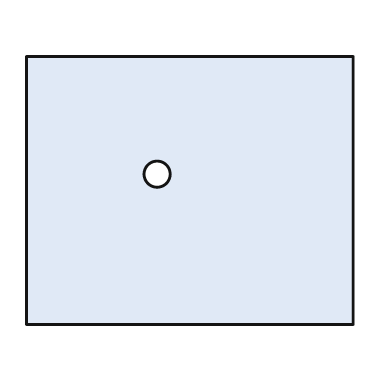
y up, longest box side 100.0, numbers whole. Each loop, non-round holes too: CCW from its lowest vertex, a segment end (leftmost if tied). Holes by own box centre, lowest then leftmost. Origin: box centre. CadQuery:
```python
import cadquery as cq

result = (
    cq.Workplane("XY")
    .moveTo(-50.0, -41.0)
    .lineTo(50.0, -41.0)
    .lineTo(50.0, 41.0)
    .lineTo(-50.0, 41.0)
    .close()
    .moveTo(-10.0, 5.0)
    .circle(4.0)
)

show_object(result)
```